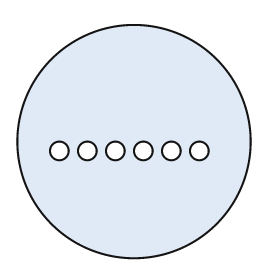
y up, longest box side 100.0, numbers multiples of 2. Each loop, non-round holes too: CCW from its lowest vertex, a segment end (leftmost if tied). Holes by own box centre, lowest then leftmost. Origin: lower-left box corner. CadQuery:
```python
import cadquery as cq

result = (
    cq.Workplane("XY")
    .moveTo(50.0, 50.0)
    .circle(50.0)
    .moveTo(18.0, 46.0)
    .circle(4.0)
    .moveTo(30.0, 46.0)
    .circle(4.0)
    .moveTo(42.0, 46.0)
    .circle(4.0)
    .moveTo(54.0, 46.0)
    .circle(4.0)
    .moveTo(66.0, 46.0)
    .circle(4.0)
    .moveTo(78.0, 46.0)
    .circle(4.0)
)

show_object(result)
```